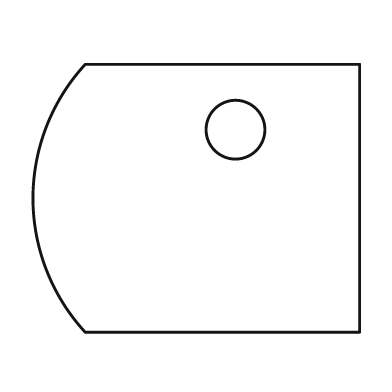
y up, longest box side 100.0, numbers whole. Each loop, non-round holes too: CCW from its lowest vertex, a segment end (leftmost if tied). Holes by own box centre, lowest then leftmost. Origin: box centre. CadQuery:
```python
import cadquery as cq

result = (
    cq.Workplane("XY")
    .moveTo(-34.0, -41.0)
    .lineTo(50.0, -41.0)
    .lineTo(50.0, 41.0)
    .lineTo(-34.0, 41.0)
    .threePointArc((-50.0, 0.0), (-34.0, -41.0))
    .close()
    .moveTo(12.0, 21.0)
    .circle(9.0)
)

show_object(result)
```